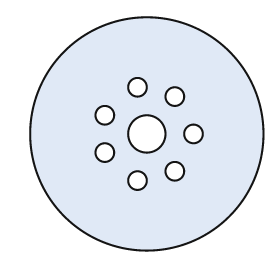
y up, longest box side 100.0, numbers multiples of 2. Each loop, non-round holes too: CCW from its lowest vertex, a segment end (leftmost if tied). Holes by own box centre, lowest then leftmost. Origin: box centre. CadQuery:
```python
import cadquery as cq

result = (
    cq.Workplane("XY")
    .moveTo(0.0, 0.0)
    .circle(50.0)
    .moveTo(-4.0, -20.0)
    .circle(4.0)
    .moveTo(12.0, -16.0)
    .circle(4.0)
    .moveTo(-18.0, -8.0)
    .circle(4.0)
    .moveTo(0.0, 0.0)
    .circle(8.0)
    .moveTo(20.0, 0.0)
    .circle(4.0)
    .moveTo(-18.0, 8.0)
    .circle(4.0)
    .moveTo(12.0, 16.0)
    .circle(4.0)
    .moveTo(-4.0, 20.0)
    .circle(4.0)
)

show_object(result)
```